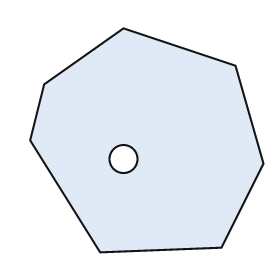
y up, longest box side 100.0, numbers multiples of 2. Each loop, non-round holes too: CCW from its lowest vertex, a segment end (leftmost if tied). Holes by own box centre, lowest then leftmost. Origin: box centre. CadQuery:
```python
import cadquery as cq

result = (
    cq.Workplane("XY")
    .moveTo(-20.0, -48.0)
    .lineTo(32.0, -46.0)
    .lineTo(50.0, -10.0)
    .lineTo(38.0, 32.0)
    .lineTo(-10.0, 48.0)
    .lineTo(-44.0, 24.0)
    .lineTo(-50.0, 0.0)
    .close()
    .moveTo(-10.0, -8.0)
    .circle(6.0)
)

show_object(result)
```